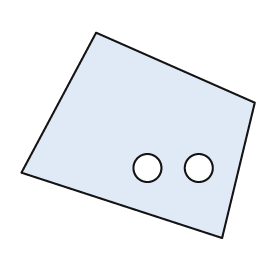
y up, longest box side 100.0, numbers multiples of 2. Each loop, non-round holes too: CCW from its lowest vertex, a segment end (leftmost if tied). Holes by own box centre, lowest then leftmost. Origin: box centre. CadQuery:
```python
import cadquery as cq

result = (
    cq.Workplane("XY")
    .moveTo(36.0, -44.0)
    .lineTo(50.0, 14.0)
    .lineTo(-18.0, 44.0)
    .lineTo(-50.0, -16.0)
    .close()
    .moveTo(4.0, -14.0)
    .circle(6.0)
    .moveTo(26.0, -14.0)
    .circle(6.0)
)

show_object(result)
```